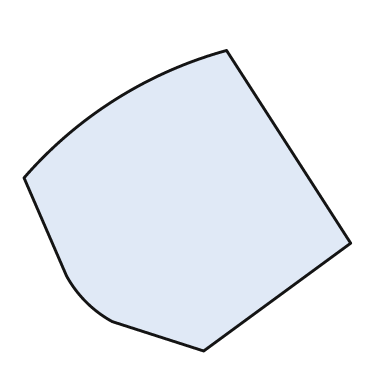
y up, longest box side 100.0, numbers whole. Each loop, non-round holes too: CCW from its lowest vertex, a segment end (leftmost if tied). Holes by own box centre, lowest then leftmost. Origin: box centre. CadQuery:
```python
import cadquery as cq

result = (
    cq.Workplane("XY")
    .moveTo(5.0, -46.0)
    .lineTo(50.0, -13.0)
    .lineTo(12.0, 46.0)
    .threePointArc((-22.0, 31.0), (-50.0, 7.0))
    .lineTo(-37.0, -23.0)
    .threePointArc((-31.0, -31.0), (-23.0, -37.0))
    .close()
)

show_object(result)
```